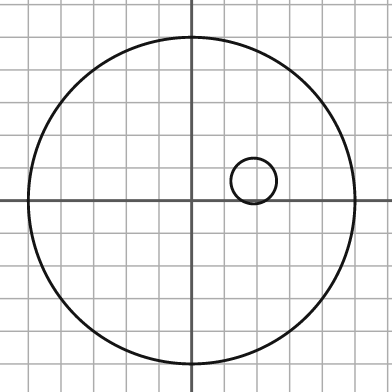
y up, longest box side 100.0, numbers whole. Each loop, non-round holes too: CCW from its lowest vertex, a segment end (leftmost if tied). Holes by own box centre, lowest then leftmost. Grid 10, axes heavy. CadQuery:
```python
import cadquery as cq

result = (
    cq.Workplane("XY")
    .moveTo(0.0, 0.0)
    .circle(50.0)
    .moveTo(19.0, 6.0)
    .circle(7.0)
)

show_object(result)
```